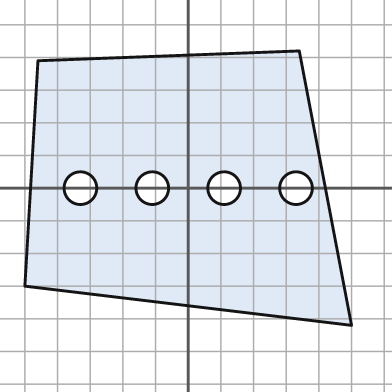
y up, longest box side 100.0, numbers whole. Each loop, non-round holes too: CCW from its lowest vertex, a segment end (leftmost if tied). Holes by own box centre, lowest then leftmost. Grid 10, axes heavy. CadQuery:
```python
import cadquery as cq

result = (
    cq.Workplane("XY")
    .moveTo(50.0, -42.0)
    .lineTo(34.0, 42.0)
    .lineTo(-46.0, 39.0)
    .lineTo(-50.0, -30.0)
    .close()
    .moveTo(-33.0, 0.0)
    .circle(5.0)
    .moveTo(-11.0, 0.0)
    .circle(5.0)
    .moveTo(11.0, 0.0)
    .circle(5.0)
    .moveTo(33.0, 0.0)
    .circle(5.0)
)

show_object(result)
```